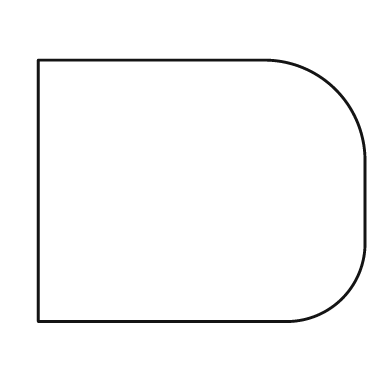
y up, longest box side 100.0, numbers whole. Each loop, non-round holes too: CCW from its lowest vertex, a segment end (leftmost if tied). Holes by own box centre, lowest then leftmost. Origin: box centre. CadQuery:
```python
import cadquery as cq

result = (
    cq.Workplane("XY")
    .moveTo(-50.0, -40.0)
    .lineTo(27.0, -40.0)
    .threePointArc((43.0, -33.0), (50.0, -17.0))
    .lineTo(50.0, 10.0)
    .threePointArc((41.0, 31.0), (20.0, 40.0))
    .lineTo(-50.0, 40.0)
    .close()
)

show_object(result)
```